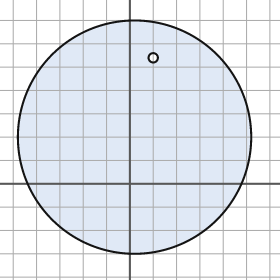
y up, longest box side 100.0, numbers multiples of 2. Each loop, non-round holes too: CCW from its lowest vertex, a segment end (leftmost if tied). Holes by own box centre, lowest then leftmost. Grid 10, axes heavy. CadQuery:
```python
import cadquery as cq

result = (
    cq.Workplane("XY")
    .moveTo(2.0, 20.0)
    .circle(50.0)
    .moveTo(10.0, 54.0)
    .circle(2.0)
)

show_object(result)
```